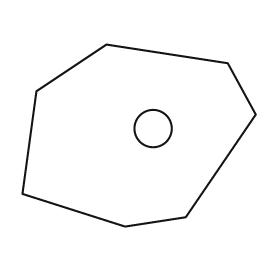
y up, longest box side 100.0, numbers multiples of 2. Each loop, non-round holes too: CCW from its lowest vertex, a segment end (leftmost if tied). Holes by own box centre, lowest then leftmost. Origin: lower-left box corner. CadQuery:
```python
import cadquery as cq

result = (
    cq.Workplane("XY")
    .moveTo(44.0, 0.0)
    .lineTo(70.0, 4.0)
    .lineTo(100.0, 48.0)
    .lineTo(88.0, 70.0)
    .lineTo(36.0, 78.0)
    .lineTo(6.0, 58.0)
    .lineTo(0.0, 14.0)
    .close()
    .moveTo(56.0, 42.0)
    .circle(8.0)
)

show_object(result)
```